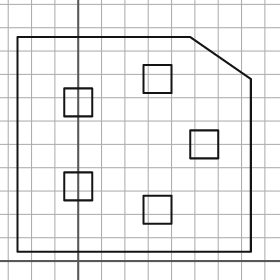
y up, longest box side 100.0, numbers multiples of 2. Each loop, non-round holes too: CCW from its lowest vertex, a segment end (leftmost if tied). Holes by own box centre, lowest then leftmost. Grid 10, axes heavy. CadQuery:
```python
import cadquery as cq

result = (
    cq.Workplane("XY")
    .moveTo(-26.0, 4.0)
    .lineTo(74.0, 4.0)
    .lineTo(74.0, 78.0)
    .lineTo(48.0, 96.0)
    .lineTo(-26.0, 96.0)
    .close()
    .moveTo(28.0, 16.0)
    .lineTo(40.0, 16.0)
    .lineTo(40.0, 28.0)
    .lineTo(28.0, 28.0)
    .close()
    .moveTo(-6.0, 26.0)
    .lineTo(6.0, 26.0)
    .lineTo(6.0, 38.0)
    .lineTo(-6.0, 38.0)
    .close()
    .moveTo(48.0, 44.0)
    .lineTo(60.0, 44.0)
    .lineTo(60.0, 56.0)
    .lineTo(48.0, 56.0)
    .close()
    .moveTo(-6.0, 62.0)
    .lineTo(6.0, 62.0)
    .lineTo(6.0, 74.0)
    .lineTo(-6.0, 74.0)
    .close()
    .moveTo(28.0, 72.0)
    .lineTo(40.0, 72.0)
    .lineTo(40.0, 84.0)
    .lineTo(28.0, 84.0)
    .close()
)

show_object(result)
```